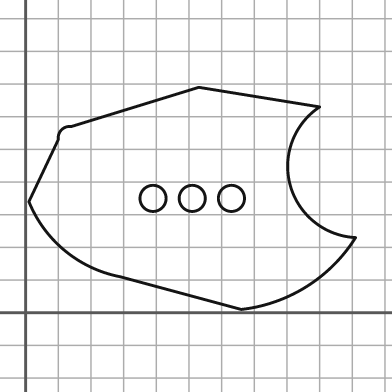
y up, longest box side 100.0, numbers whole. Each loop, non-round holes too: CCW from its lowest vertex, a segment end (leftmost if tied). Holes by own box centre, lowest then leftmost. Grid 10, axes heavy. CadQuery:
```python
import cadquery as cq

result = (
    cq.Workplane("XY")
    .moveTo(66.0, 1.0)
    .threePointArc((86.0, 8.0), (101.0, 23.0))
    .threePointArc((81.0, 39.0), (90.0, 63.0))
    .lineTo(53.0, 69.0)
    .lineTo(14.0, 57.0)
    .threePointArc((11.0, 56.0), (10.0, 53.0))
    .lineTo(1.0, 34.0)
    .threePointArc((12.0, 19.0), (29.0, 11.0))
    .close()
    .moveTo(39.0, 35.0)
    .circle(4.0)
    .moveTo(51.0, 35.0)
    .circle(4.0)
    .moveTo(63.0, 35.0)
    .circle(4.0)
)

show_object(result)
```